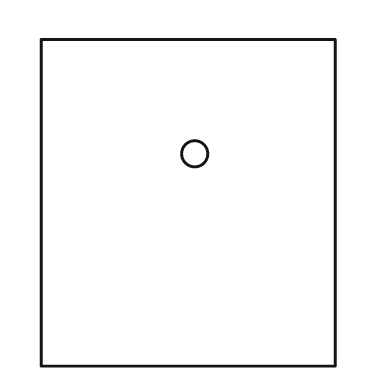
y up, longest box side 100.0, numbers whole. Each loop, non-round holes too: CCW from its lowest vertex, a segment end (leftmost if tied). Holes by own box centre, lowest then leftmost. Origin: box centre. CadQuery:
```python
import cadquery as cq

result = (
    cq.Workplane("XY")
    .moveTo(-45.0, -50.0)
    .lineTo(45.0, -50.0)
    .lineTo(45.0, 50.0)
    .lineTo(-45.0, 50.0)
    .close()
    .moveTo(2.0, 15.0)
    .circle(4.0)
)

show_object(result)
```